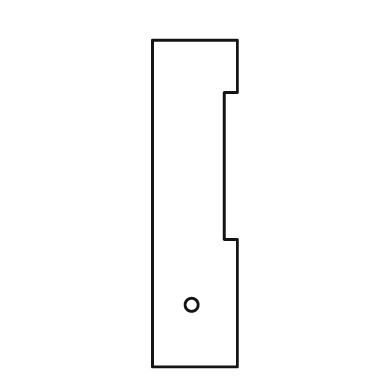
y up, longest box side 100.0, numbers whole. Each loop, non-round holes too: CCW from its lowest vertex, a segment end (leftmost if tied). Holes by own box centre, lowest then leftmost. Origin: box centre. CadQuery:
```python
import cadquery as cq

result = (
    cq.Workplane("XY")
    .moveTo(-13.0, -50.0)
    .lineTo(13.0, -50.0)
    .lineTo(13.0, -11.0)
    .lineTo(9.0, -11.0)
    .lineTo(9.0, 34.0)
    .lineTo(13.0, 34.0)
    .lineTo(13.0, 50.0)
    .lineTo(-13.0, 50.0)
    .close()
    .moveTo(-1.0, -31.0)
    .circle(2.0)
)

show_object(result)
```